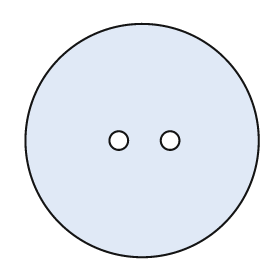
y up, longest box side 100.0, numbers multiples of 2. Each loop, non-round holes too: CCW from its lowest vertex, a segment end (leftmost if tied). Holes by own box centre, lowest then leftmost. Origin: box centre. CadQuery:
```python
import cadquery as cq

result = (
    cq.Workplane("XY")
    .moveTo(0.0, 0.0)
    .circle(50.0)
    .moveTo(-10.0, 0.0)
    .circle(4.0)
    .moveTo(12.0, 0.0)
    .circle(4.0)
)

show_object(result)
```